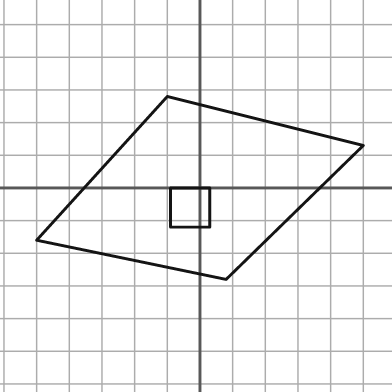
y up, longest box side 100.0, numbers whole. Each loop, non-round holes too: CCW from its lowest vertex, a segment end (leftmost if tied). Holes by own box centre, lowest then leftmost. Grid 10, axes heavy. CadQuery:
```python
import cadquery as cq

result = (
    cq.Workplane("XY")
    .moveTo(8.0, -28.0)
    .lineTo(50.0, 13.0)
    .lineTo(-10.0, 28.0)
    .lineTo(-50.0, -16.0)
    .close()
    .moveTo(-9.0, -12.0)
    .lineTo(3.0, -12.0)
    .lineTo(3.0, 0.0)
    .lineTo(-9.0, 0.0)
    .close()
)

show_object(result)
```